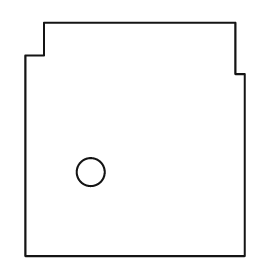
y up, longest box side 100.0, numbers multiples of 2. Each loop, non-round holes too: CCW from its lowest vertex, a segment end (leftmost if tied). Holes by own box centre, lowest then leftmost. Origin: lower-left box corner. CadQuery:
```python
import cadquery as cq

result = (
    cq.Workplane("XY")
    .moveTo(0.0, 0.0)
    .lineTo(94.0, 0.0)
    .lineTo(94.0, 78.0)
    .lineTo(90.0, 78.0)
    .lineTo(90.0, 100.0)
    .lineTo(8.0, 100.0)
    .lineTo(8.0, 86.0)
    .lineTo(0.0, 86.0)
    .close()
    .moveTo(28.0, 36.0)
    .circle(6.0)
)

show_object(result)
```